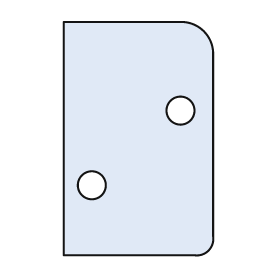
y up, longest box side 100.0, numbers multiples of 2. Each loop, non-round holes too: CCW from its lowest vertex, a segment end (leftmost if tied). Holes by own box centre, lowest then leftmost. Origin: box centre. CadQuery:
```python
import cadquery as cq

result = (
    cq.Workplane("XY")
    .moveTo(-32.0, -50.0)
    .lineTo(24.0, -50.0)
    .threePointArc((30.0, -48.0), (32.0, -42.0))
    .lineTo(32.0, 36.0)
    .threePointArc((28.0, 46.0), (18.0, 50.0))
    .lineTo(-32.0, 50.0)
    .close()
    .moveTo(-20.0, -20.0)
    .circle(6.0)
    .moveTo(18.0, 12.0)
    .circle(6.0)
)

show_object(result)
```